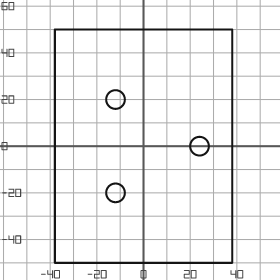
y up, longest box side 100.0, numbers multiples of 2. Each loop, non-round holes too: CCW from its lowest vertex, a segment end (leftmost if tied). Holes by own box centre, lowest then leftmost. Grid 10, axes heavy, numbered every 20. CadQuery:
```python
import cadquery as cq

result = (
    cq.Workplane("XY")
    .moveTo(-38.0, -50.0)
    .lineTo(38.0, -50.0)
    .lineTo(38.0, 50.0)
    .lineTo(-38.0, 50.0)
    .close()
    .moveTo(-12.0, -20.0)
    .circle(4.0)
    .moveTo(24.0, 0.0)
    .circle(4.0)
    .moveTo(-12.0, 20.0)
    .circle(4.0)
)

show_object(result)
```